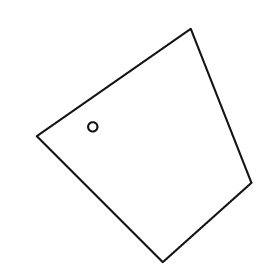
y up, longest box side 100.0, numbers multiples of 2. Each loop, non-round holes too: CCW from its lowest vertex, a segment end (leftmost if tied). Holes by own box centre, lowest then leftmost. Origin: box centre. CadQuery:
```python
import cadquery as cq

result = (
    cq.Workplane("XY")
    .moveTo(8.0, -50.0)
    .lineTo(46.0, -16.0)
    .lineTo(20.0, 50.0)
    .lineTo(-46.0, 4.0)
    .close()
    .moveTo(-22.0, 8.0)
    .circle(2.0)
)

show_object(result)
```